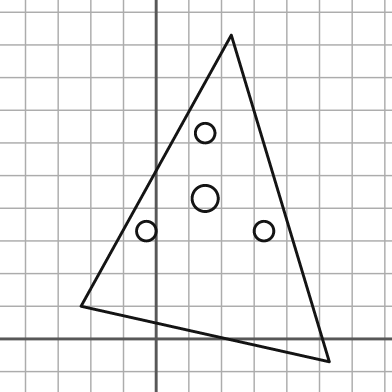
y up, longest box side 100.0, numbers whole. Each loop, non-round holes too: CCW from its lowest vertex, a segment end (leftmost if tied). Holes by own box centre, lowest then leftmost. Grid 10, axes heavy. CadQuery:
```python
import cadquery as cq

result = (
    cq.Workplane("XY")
    .moveTo(53.0, -7.0)
    .lineTo(23.0, 93.0)
    .lineTo(-23.0, 10.0)
    .close()
    .moveTo(-3.0, 33.0)
    .circle(3.0)
    .moveTo(33.0, 33.0)
    .circle(3.0)
    .moveTo(15.0, 43.0)
    .circle(4.0)
    .moveTo(15.0, 63.0)
    .circle(3.0)
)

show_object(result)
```